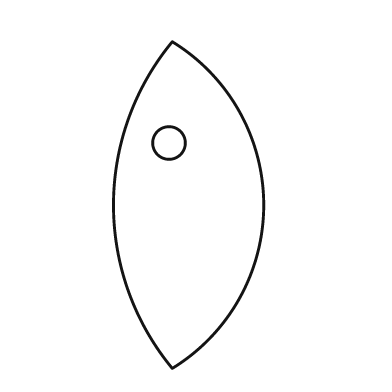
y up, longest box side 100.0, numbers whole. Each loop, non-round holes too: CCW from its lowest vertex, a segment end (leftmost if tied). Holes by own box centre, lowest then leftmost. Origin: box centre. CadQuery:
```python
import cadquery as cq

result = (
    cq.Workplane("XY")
    .moveTo(-5.0, -50.0)
    .threePointArc((23.0, 0.0), (-5.0, 50.0))
    .threePointArc((-23.0, 0.0), (-5.0, -50.0))
    .close()
    .moveTo(-6.0, 19.0)
    .circle(5.0)
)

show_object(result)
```